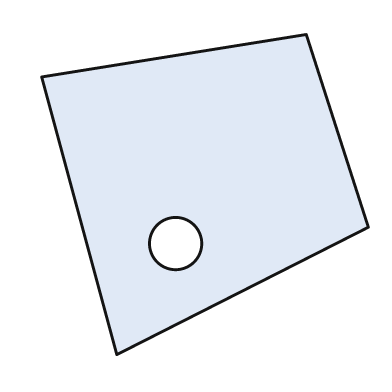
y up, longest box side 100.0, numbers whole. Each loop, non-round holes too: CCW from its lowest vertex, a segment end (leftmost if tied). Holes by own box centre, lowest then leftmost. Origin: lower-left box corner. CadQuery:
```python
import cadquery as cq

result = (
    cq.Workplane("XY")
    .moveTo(23.0, 0.0)
    .lineTo(100.0, 39.0)
    .lineTo(81.0, 98.0)
    .lineTo(0.0, 85.0)
    .close()
    .moveTo(41.0, 34.0)
    .circle(8.0)
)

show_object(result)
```